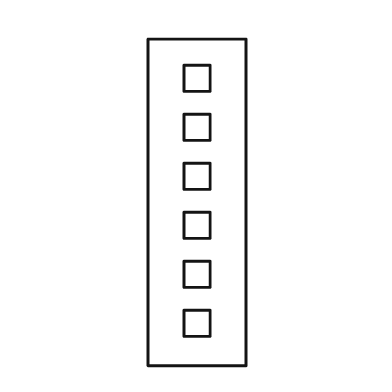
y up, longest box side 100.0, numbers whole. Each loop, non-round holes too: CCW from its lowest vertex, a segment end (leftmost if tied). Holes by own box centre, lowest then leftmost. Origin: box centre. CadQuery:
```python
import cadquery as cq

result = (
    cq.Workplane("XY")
    .moveTo(-15.0, -50.0)
    .lineTo(15.0, -50.0)
    .lineTo(15.0, 50.0)
    .lineTo(-15.0, 50.0)
    .close()
    .moveTo(-4.0, -41.0)
    .lineTo(4.0, -41.0)
    .lineTo(4.0, -33.0)
    .lineTo(-4.0, -33.0)
    .close()
    .moveTo(-4.0, -26.0)
    .lineTo(4.0, -26.0)
    .lineTo(4.0, -18.0)
    .lineTo(-4.0, -18.0)
    .close()
    .moveTo(-4.0, -11.0)
    .lineTo(4.0, -11.0)
    .lineTo(4.0, -3.0)
    .lineTo(-4.0, -3.0)
    .close()
    .moveTo(-4.0, 4.0)
    .lineTo(4.0, 4.0)
    .lineTo(4.0, 12.0)
    .lineTo(-4.0, 12.0)
    .close()
    .moveTo(-4.0, 19.0)
    .lineTo(4.0, 19.0)
    .lineTo(4.0, 27.0)
    .lineTo(-4.0, 27.0)
    .close()
    .moveTo(-4.0, 34.0)
    .lineTo(4.0, 34.0)
    .lineTo(4.0, 42.0)
    .lineTo(-4.0, 42.0)
    .close()
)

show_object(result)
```